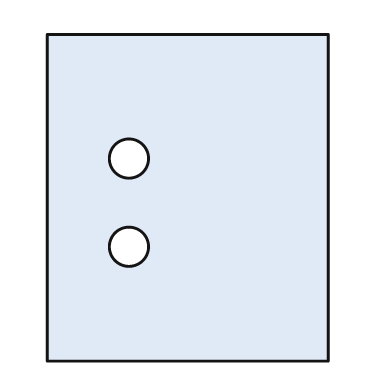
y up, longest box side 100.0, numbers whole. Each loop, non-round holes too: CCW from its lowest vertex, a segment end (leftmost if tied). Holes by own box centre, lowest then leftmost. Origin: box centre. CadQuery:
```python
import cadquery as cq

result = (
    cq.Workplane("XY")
    .moveTo(-43.0, -50.0)
    .lineTo(43.0, -50.0)
    .lineTo(43.0, 50.0)
    .lineTo(-43.0, 50.0)
    .close()
    .moveTo(-18.0, -15.0)
    .circle(6.0)
    .moveTo(-18.0, 12.0)
    .circle(6.0)
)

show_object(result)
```